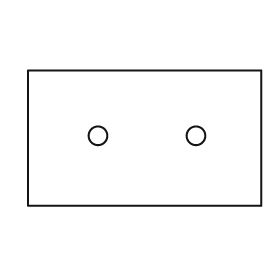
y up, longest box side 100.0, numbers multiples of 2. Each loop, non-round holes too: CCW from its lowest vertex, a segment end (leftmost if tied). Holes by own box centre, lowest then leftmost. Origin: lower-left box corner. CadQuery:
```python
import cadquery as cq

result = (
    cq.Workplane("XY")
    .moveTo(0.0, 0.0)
    .lineTo(100.0, 0.0)
    .lineTo(100.0, 58.0)
    .lineTo(0.0, 58.0)
    .close()
    .moveTo(30.0, 30.0)
    .circle(4.0)
    .moveTo(72.0, 30.0)
    .circle(4.0)
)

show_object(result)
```